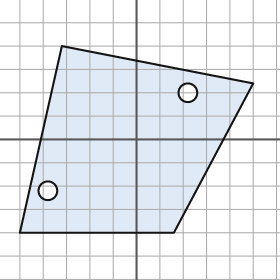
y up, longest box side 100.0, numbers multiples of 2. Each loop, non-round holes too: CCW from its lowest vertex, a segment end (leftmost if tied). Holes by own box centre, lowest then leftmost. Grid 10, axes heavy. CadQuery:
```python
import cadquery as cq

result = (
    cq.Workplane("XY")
    .moveTo(-50.0, -40.0)
    .lineTo(16.0, -40.0)
    .lineTo(50.0, 24.0)
    .lineTo(-32.0, 40.0)
    .close()
    .moveTo(-38.0, -22.0)
    .circle(4.0)
    .moveTo(22.0, 20.0)
    .circle(4.0)
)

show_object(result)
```